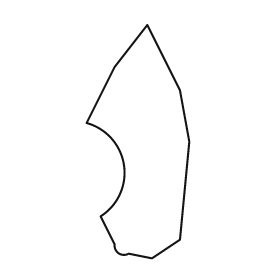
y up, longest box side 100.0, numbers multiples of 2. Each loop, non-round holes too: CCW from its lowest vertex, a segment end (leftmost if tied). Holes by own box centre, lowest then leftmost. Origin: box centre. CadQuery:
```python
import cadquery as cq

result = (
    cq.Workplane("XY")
    .moveTo(6.0, -50.0)
    .lineTo(18.0, -42.0)
    .lineTo(22.0, 0.0)
    .lineTo(18.0, 22.0)
    .lineTo(4.0, 50.0)
    .lineTo(-10.0, 32.0)
    .lineTo(-22.0, 8.0)
    .threePointArc((-6.0, -10.0), (-16.0, -32.0))
    .lineTo(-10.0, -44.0)
    .threePointArc((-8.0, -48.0), (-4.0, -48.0))
    .close()
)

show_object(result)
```